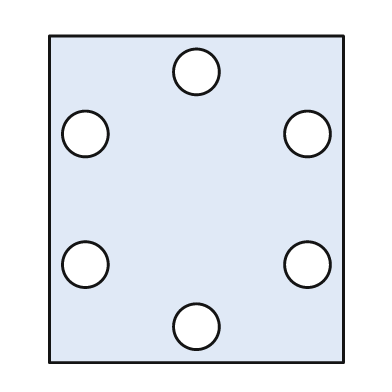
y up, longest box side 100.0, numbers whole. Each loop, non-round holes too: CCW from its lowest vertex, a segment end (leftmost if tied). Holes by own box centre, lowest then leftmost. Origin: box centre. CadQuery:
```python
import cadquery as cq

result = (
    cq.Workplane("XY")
    .moveTo(-45.0, -50.0)
    .lineTo(45.0, -50.0)
    .lineTo(45.0, 50.0)
    .lineTo(-45.0, 50.0)
    .close()
    .moveTo(0.0, -39.0)
    .circle(7.0)
    .moveTo(-34.0, -20.0)
    .circle(7.0)
    .moveTo(34.0, -20.0)
    .circle(7.0)
    .moveTo(-34.0, 20.0)
    .circle(7.0)
    .moveTo(34.0, 20.0)
    .circle(7.0)
    .moveTo(0.0, 39.0)
    .circle(7.0)
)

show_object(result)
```